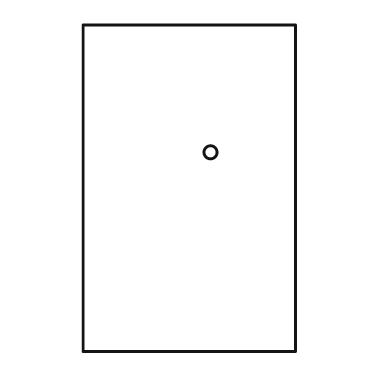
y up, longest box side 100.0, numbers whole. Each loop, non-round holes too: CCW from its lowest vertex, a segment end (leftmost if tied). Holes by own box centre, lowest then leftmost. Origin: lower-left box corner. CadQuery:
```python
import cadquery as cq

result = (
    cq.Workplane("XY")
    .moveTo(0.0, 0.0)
    .lineTo(65.0, 0.0)
    .lineTo(65.0, 100.0)
    .lineTo(0.0, 100.0)
    .close()
    .moveTo(39.0, 61.0)
    .circle(2.0)
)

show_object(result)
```